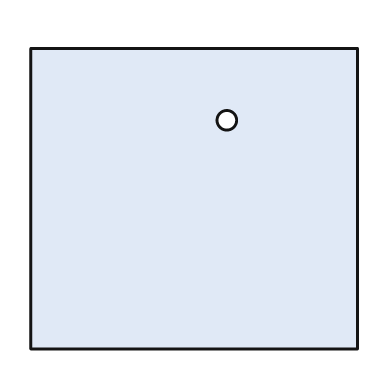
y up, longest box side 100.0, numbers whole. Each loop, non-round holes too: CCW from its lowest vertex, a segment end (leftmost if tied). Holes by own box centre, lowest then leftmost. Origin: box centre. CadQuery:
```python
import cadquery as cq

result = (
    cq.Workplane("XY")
    .moveTo(-50.0, -46.0)
    .lineTo(50.0, -46.0)
    .lineTo(50.0, 46.0)
    .lineTo(-50.0, 46.0)
    .close()
    .moveTo(10.0, 24.0)
    .circle(3.0)
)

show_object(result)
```